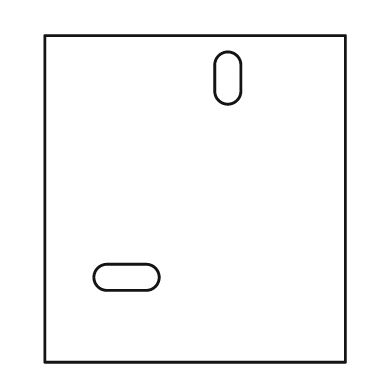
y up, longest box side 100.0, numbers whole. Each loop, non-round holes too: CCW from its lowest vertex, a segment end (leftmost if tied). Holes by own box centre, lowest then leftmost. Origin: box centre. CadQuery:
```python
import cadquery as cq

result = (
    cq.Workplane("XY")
    .moveTo(-46.0, -50.0)
    .lineTo(46.0, -50.0)
    .lineTo(46.0, 50.0)
    .lineTo(-46.0, 50.0)
    .close()
    .moveTo(-27.0, -28.0)
    .lineTo(-15.0, -28.0)
    .threePointArc((-11.0, -24.0), (-15.0, -20.0))
    .lineTo(-27.0, -20.0)
    .threePointArc((-31.0, -24.0), (-27.0, -28.0))
    .close()
    .moveTo(6.0, 33.0)
    .threePointArc((10.0, 29.0), (14.0, 33.0))
    .lineTo(14.0, 41.0)
    .threePointArc((10.0, 45.0), (6.0, 41.0))
    .close()
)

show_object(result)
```